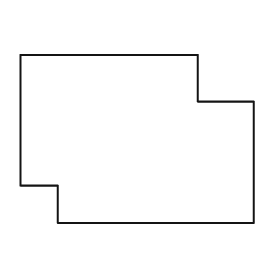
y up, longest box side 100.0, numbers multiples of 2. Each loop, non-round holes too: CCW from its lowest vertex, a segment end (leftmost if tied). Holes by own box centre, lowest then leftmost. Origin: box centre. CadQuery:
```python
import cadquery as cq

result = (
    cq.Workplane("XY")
    .moveTo(-34.0, -36.0)
    .lineTo(50.0, -36.0)
    .lineTo(50.0, 16.0)
    .lineTo(26.0, 16.0)
    .lineTo(26.0, 36.0)
    .lineTo(-50.0, 36.0)
    .lineTo(-50.0, -20.0)
    .lineTo(-34.0, -20.0)
    .close()
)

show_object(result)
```